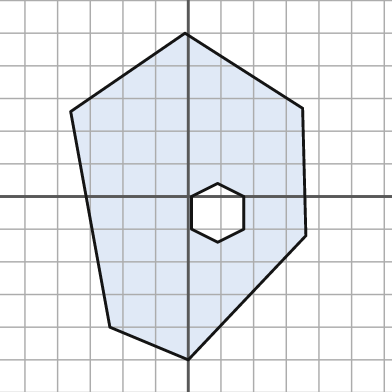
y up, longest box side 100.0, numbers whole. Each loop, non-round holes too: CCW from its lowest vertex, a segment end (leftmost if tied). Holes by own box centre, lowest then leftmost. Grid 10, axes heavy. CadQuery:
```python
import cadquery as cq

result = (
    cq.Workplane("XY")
    .moveTo(0.0, -50.0)
    .lineTo(36.0, -12.0)
    .lineTo(35.0, 27.0)
    .lineTo(-1.0, 50.0)
    .lineTo(-36.0, 26.0)
    .lineTo(-24.0, -40.0)
    .close()
    .moveTo(9.0, -14.0)
    .lineTo(17.0, -10.0)
    .lineTo(17.0, 0.0)
    .lineTo(9.0, 4.0)
    .lineTo(1.0, 0.0)
    .lineTo(1.0, -10.0)
    .close()
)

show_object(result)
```